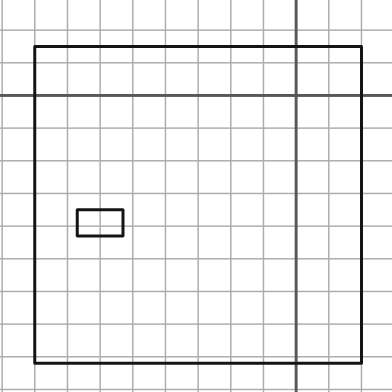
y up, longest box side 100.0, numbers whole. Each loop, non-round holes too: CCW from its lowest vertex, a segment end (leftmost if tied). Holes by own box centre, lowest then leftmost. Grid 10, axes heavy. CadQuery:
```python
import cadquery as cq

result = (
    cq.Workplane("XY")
    .moveTo(-80.0, -82.0)
    .lineTo(20.0, -82.0)
    .lineTo(20.0, 15.0)
    .lineTo(-80.0, 15.0)
    .close()
    .moveTo(-67.0, -43.0)
    .lineTo(-53.0, -43.0)
    .lineTo(-53.0, -35.0)
    .lineTo(-67.0, -35.0)
    .close()
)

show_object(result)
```